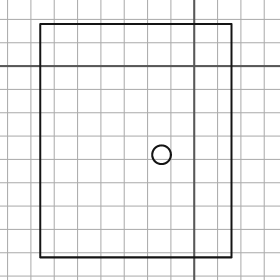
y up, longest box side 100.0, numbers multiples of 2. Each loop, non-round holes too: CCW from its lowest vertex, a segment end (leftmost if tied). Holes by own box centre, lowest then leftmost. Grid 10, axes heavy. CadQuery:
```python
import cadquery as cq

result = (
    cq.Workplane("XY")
    .moveTo(-66.0, -82.0)
    .lineTo(16.0, -82.0)
    .lineTo(16.0, 18.0)
    .lineTo(-66.0, 18.0)
    .close()
    .moveTo(-14.0, -38.0)
    .circle(4.0)
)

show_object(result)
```